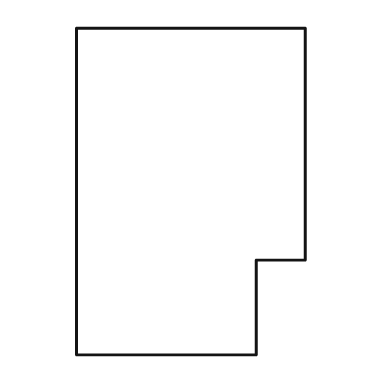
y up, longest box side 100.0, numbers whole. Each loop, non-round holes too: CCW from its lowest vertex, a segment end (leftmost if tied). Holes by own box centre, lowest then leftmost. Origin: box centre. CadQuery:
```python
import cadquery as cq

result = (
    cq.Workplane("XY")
    .moveTo(-35.0, -50.0)
    .lineTo(20.0, -50.0)
    .lineTo(20.0, -21.0)
    .lineTo(35.0, -21.0)
    .lineTo(35.0, 50.0)
    .lineTo(-35.0, 50.0)
    .close()
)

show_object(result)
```